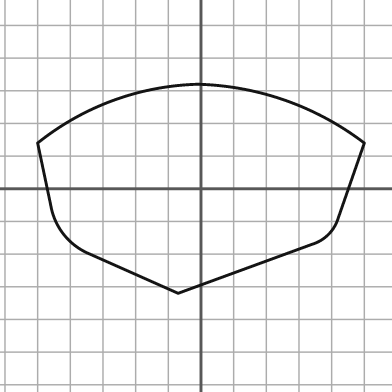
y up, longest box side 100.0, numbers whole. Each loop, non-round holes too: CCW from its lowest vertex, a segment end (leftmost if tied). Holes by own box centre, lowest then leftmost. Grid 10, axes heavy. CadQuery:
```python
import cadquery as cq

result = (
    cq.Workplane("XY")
    .moveTo(-7.0, -32.0)
    .lineTo(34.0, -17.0)
    .threePointArc((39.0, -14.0), (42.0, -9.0))
    .lineTo(50.0, 14.0)
    .threePointArc((26.0, 27.0), (-1.0, 32.0))
    .threePointArc((-27.0, 27.0), (-50.0, 14.0))
    .lineTo(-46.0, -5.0)
    .threePointArc((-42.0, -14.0), (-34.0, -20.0))
    .close()
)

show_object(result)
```